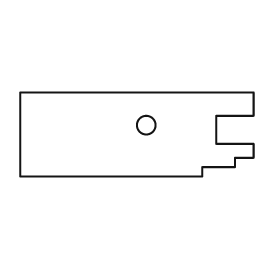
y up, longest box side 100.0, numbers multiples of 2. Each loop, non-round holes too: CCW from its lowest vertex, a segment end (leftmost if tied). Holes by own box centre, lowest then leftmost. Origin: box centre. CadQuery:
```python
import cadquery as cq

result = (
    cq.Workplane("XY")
    .moveTo(-50.0, -18.0)
    .lineTo(28.0, -18.0)
    .lineTo(28.0, -14.0)
    .lineTo(42.0, -14.0)
    .lineTo(42.0, -10.0)
    .lineTo(50.0, -10.0)
    .lineTo(50.0, -4.0)
    .lineTo(34.0, -4.0)
    .lineTo(34.0, 8.0)
    .lineTo(50.0, 8.0)
    .lineTo(50.0, 18.0)
    .lineTo(-50.0, 18.0)
    .close()
    .moveTo(4.0, 4.0)
    .circle(4.0)
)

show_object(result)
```